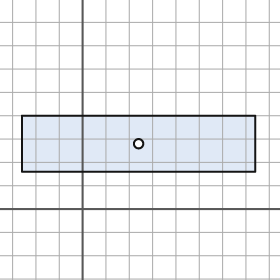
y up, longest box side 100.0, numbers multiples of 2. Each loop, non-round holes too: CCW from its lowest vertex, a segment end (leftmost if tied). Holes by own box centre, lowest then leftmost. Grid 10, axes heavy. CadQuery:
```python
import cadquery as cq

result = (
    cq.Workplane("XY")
    .moveTo(-26.0, 16.0)
    .lineTo(74.0, 16.0)
    .lineTo(74.0, 40.0)
    .lineTo(-26.0, 40.0)
    .close()
    .moveTo(24.0, 28.0)
    .circle(2.0)
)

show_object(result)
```